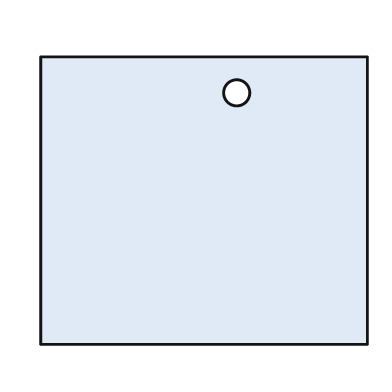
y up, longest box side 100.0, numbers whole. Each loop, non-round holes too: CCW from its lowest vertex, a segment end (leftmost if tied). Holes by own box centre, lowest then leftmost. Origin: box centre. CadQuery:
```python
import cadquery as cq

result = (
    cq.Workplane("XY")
    .moveTo(-50.0, -44.0)
    .lineTo(50.0, -44.0)
    .lineTo(50.0, 44.0)
    .lineTo(-50.0, 44.0)
    .close()
    .moveTo(10.0, 33.0)
    .circle(4.0)
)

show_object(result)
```